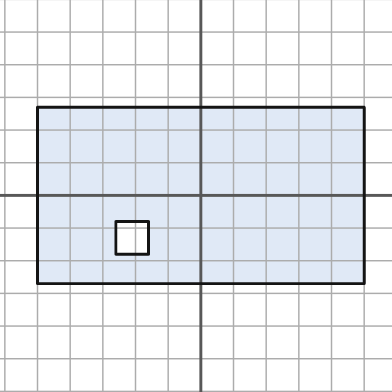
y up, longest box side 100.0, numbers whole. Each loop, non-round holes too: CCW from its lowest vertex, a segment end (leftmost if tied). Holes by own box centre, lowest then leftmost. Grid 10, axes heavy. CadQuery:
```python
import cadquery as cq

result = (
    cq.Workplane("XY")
    .moveTo(-50.0, -27.0)
    .lineTo(50.0, -27.0)
    .lineTo(50.0, 27.0)
    .lineTo(-50.0, 27.0)
    .close()
    .moveTo(-26.0, -18.0)
    .lineTo(-16.0, -18.0)
    .lineTo(-16.0, -8.0)
    .lineTo(-26.0, -8.0)
    .close()
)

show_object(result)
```